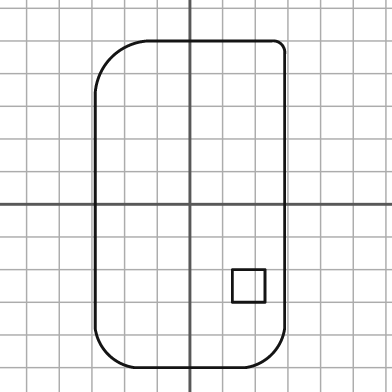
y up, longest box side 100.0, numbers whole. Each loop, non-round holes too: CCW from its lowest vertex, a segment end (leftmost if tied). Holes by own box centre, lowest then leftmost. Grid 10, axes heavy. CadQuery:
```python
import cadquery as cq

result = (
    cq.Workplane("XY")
    .moveTo(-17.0, -50.0)
    .lineTo(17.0, -50.0)
    .threePointArc((25.0, -46.0), (29.0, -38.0))
    .lineTo(29.0, 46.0)
    .threePointArc((28.0, 49.0), (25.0, 50.0))
    .lineTo(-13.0, 50.0)
    .threePointArc((-24.0, 45.0), (-29.0, 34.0))
    .lineTo(-29.0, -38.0)
    .threePointArc((-25.0, -46.0), (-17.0, -50.0))
    .close()
    .moveTo(13.0, -30.0)
    .lineTo(23.0, -30.0)
    .lineTo(23.0, -20.0)
    .lineTo(13.0, -20.0)
    .close()
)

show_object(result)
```